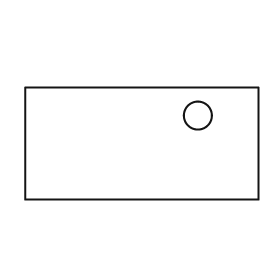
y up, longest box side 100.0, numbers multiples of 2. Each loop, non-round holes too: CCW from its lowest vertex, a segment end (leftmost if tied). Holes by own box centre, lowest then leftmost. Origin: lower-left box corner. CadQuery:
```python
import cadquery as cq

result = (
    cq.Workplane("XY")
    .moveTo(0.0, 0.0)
    .lineTo(100.0, 0.0)
    .lineTo(100.0, 48.0)
    .lineTo(0.0, 48.0)
    .close()
    .moveTo(74.0, 36.0)
    .circle(6.0)
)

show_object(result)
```